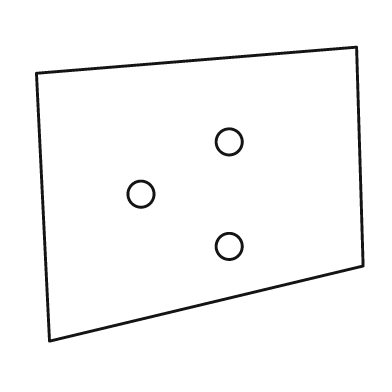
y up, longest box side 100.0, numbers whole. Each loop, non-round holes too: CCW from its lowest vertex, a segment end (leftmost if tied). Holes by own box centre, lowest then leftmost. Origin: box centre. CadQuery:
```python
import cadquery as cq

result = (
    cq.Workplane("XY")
    .moveTo(-46.0, -45.0)
    .lineTo(50.0, -22.0)
    .lineTo(48.0, 45.0)
    .lineTo(-50.0, 37.0)
    .close()
    .moveTo(9.0, -16.0)
    .circle(4.0)
    .moveTo(-18.0, 0.0)
    .circle(4.0)
    .moveTo(9.0, 16.0)
    .circle(4.0)
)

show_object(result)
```